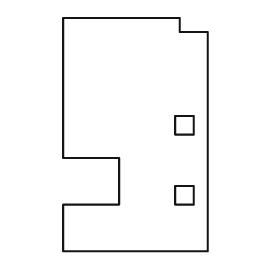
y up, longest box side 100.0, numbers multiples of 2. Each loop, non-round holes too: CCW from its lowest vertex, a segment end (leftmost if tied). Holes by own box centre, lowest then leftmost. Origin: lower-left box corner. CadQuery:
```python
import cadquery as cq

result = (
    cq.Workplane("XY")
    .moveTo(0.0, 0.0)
    .lineTo(62.0, 0.0)
    .lineTo(62.0, 94.0)
    .lineTo(50.0, 94.0)
    .lineTo(50.0, 100.0)
    .lineTo(0.0, 100.0)
    .lineTo(0.0, 40.0)
    .lineTo(24.0, 40.0)
    .lineTo(24.0, 20.0)
    .lineTo(0.0, 20.0)
    .close()
    .moveTo(48.0, 20.0)
    .lineTo(56.0, 20.0)
    .lineTo(56.0, 28.0)
    .lineTo(48.0, 28.0)
    .close()
    .moveTo(48.0, 50.0)
    .lineTo(56.0, 50.0)
    .lineTo(56.0, 58.0)
    .lineTo(48.0, 58.0)
    .close()
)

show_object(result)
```